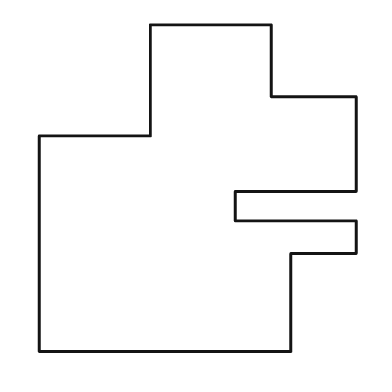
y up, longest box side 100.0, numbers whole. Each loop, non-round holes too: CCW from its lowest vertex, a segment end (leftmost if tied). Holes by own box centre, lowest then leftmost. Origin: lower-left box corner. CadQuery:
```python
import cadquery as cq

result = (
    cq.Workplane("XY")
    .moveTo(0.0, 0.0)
    .lineTo(77.0, 0.0)
    .lineTo(77.0, 30.0)
    .lineTo(97.0, 30.0)
    .lineTo(97.0, 40.0)
    .lineTo(60.0, 40.0)
    .lineTo(60.0, 49.0)
    .lineTo(97.0, 49.0)
    .lineTo(97.0, 78.0)
    .lineTo(71.0, 78.0)
    .lineTo(71.0, 100.0)
    .lineTo(34.0, 100.0)
    .lineTo(34.0, 66.0)
    .lineTo(0.0, 66.0)
    .close()
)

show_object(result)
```